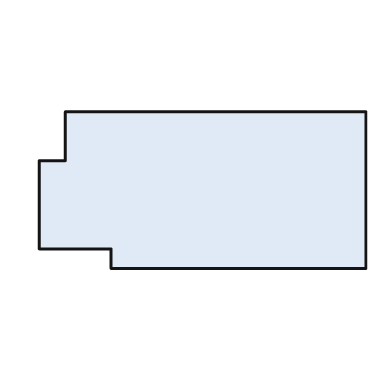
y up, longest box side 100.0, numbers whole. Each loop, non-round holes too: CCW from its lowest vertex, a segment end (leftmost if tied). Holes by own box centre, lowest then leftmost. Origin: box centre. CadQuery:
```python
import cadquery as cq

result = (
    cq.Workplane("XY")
    .moveTo(-28.0, -24.0)
    .lineTo(50.0, -24.0)
    .lineTo(50.0, 24.0)
    .lineTo(-42.0, 24.0)
    .lineTo(-42.0, 9.0)
    .lineTo(-50.0, 9.0)
    .lineTo(-50.0, -18.0)
    .lineTo(-28.0, -18.0)
    .close()
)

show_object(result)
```